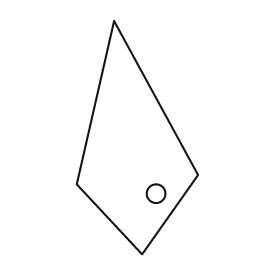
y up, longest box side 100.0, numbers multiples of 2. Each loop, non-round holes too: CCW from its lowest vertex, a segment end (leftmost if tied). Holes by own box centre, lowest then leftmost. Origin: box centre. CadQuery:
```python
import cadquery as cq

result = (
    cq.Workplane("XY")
    .moveTo(2.0, -50.0)
    .lineTo(26.0, -16.0)
    .lineTo(-10.0, 50.0)
    .lineTo(-26.0, -20.0)
    .close()
    .moveTo(8.0, -24.0)
    .circle(4.0)
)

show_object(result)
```